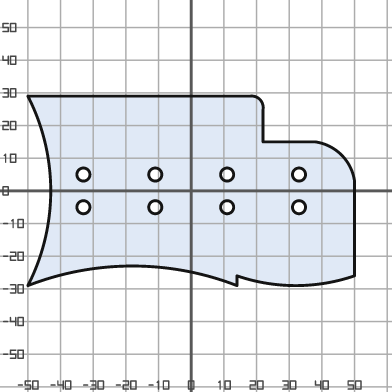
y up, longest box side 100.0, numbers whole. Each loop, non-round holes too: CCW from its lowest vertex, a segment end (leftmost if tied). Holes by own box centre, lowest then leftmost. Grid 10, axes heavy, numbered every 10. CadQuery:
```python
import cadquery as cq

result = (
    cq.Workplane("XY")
    .moveTo(-50.0, -29.0)
    .threePointArc((-18.0, -23.0), (14.0, -29.0))
    .lineTo(14.0, -26.0)
    .threePointArc((32.0, -29.0), (50.0, -26.0))
    .lineTo(50.0, 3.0)
    .threePointArc((46.0, 11.0), (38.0, 15.0))
    .lineTo(22.0, 15.0)
    .lineTo(22.0, 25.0)
    .threePointArc((21.0, 28.0), (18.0, 29.0))
    .lineTo(-50.0, 29.0)
    .threePointArc((-43.0, 0.0), (-50.0, -29.0))
    .close()
    .moveTo(-33.0, -5.0)
    .circle(2.0)
    .moveTo(-11.0, -5.0)
    .circle(2.0)
    .moveTo(11.0, -5.0)
    .circle(2.0)
    .moveTo(33.0, -5.0)
    .circle(2.0)
    .moveTo(-33.0, 5.0)
    .circle(2.0)
    .moveTo(-11.0, 5.0)
    .circle(2.0)
    .moveTo(11.0, 5.0)
    .circle(2.0)
    .moveTo(33.0, 5.0)
    .circle(2.0)
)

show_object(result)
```